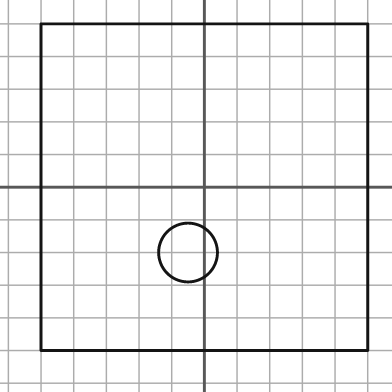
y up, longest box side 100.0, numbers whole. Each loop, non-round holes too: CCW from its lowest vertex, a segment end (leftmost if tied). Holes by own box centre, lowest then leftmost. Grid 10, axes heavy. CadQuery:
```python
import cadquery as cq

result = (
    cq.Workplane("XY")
    .moveTo(-50.0, -50.0)
    .lineTo(50.0, -50.0)
    .lineTo(50.0, 50.0)
    .lineTo(-50.0, 50.0)
    .close()
    .moveTo(-5.0, -20.0)
    .circle(9.0)
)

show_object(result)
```